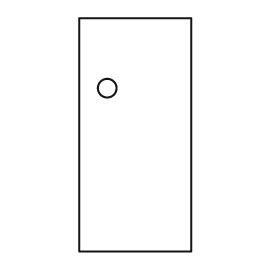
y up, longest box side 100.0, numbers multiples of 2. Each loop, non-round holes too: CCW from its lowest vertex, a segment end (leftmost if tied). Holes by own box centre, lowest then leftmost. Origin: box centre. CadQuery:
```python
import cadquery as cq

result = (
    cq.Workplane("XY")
    .moveTo(-24.0, -50.0)
    .lineTo(24.0, -50.0)
    .lineTo(24.0, 50.0)
    .lineTo(-24.0, 50.0)
    .close()
    .moveTo(-12.0, 20.0)
    .circle(4.0)
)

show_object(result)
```